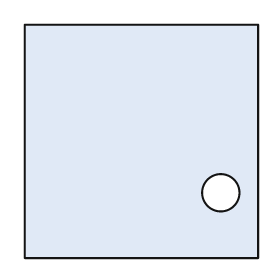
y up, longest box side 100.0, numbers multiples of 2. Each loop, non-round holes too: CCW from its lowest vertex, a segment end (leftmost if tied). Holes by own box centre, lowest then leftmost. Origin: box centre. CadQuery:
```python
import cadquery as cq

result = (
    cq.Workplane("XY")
    .moveTo(-50.0, -50.0)
    .lineTo(50.0, -50.0)
    .lineTo(50.0, 50.0)
    .lineTo(-50.0, 50.0)
    .close()
    .moveTo(34.0, -22.0)
    .circle(8.0)
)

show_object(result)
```